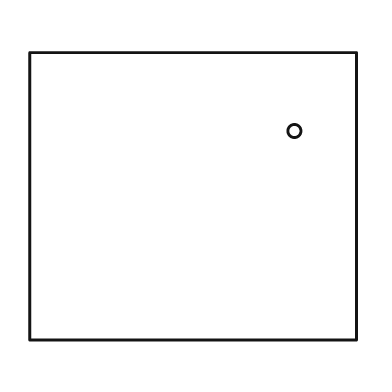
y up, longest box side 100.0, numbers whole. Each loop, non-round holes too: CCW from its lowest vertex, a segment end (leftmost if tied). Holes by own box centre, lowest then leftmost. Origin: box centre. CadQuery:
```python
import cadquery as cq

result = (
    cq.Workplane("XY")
    .moveTo(-50.0, -44.0)
    .lineTo(50.0, -44.0)
    .lineTo(50.0, 44.0)
    .lineTo(-50.0, 44.0)
    .close()
    .moveTo(31.0, 20.0)
    .circle(2.0)
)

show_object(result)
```